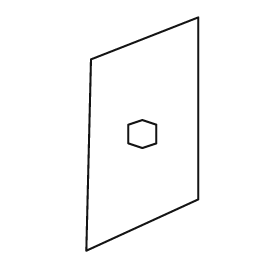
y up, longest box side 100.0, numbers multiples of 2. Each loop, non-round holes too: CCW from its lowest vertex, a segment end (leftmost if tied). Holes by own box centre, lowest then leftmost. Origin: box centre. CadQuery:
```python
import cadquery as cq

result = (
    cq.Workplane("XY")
    .moveTo(-24.0, -50.0)
    .lineTo(24.0, -28.0)
    .lineTo(24.0, 50.0)
    .lineTo(-22.0, 32.0)
    .close()
    .moveTo(0.0, -6.0)
    .lineTo(6.0, -4.0)
    .lineTo(6.0, 4.0)
    .lineTo(0.0, 6.0)
    .lineTo(-6.0, 4.0)
    .lineTo(-6.0, -4.0)
    .close()
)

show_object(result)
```